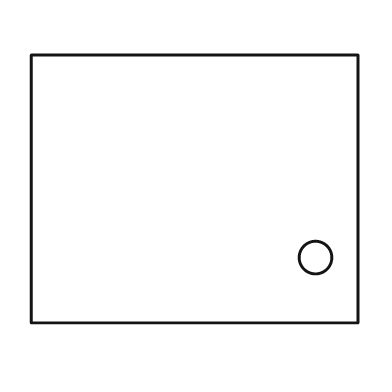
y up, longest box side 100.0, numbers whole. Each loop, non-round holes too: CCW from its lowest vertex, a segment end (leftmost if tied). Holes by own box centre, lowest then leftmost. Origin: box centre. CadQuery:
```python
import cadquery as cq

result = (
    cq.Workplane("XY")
    .moveTo(-50.0, -41.0)
    .lineTo(50.0, -41.0)
    .lineTo(50.0, 41.0)
    .lineTo(-50.0, 41.0)
    .close()
    .moveTo(37.0, -21.0)
    .circle(5.0)
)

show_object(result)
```